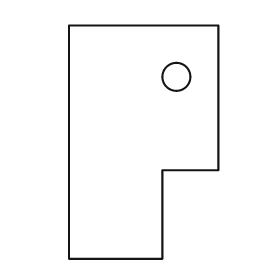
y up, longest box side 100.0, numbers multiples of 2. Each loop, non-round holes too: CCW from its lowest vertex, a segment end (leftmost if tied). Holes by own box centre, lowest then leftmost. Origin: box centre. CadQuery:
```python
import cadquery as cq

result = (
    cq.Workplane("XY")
    .moveTo(-32.0, -50.0)
    .lineTo(8.0, -50.0)
    .lineTo(8.0, -12.0)
    .lineTo(32.0, -12.0)
    .lineTo(32.0, 50.0)
    .lineTo(-32.0, 50.0)
    .close()
    .moveTo(14.0, 28.0)
    .circle(6.0)
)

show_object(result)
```